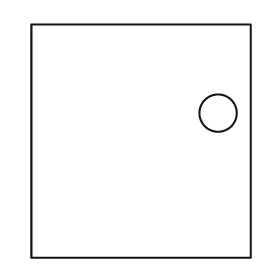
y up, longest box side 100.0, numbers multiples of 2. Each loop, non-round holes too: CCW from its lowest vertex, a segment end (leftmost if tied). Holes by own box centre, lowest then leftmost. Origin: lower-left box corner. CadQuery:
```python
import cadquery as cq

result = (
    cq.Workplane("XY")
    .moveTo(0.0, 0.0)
    .lineTo(94.0, 0.0)
    .lineTo(94.0, 100.0)
    .lineTo(0.0, 100.0)
    .close()
    .moveTo(80.0, 62.0)
    .circle(8.0)
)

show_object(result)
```